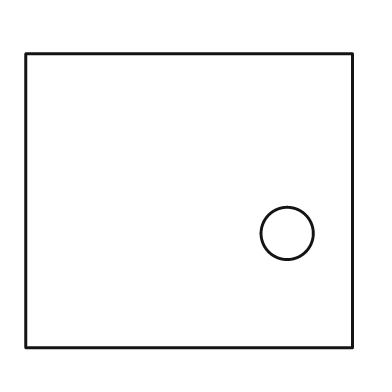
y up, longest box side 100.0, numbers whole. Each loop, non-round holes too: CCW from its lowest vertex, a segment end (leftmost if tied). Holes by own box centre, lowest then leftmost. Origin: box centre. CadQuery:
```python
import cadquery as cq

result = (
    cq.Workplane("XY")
    .moveTo(-50.0, -45.0)
    .lineTo(50.0, -45.0)
    .lineTo(50.0, 45.0)
    .lineTo(-50.0, 45.0)
    .close()
    .moveTo(30.0, -10.0)
    .circle(8.0)
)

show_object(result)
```